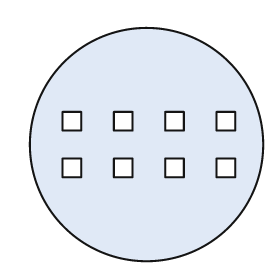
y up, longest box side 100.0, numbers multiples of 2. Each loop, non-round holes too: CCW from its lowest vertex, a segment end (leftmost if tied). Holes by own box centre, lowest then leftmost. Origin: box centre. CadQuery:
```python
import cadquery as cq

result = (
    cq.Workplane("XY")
    .moveTo(0.0, 0.0)
    .circle(50.0)
    .moveTo(-36.0, -14.0)
    .lineTo(-28.0, -14.0)
    .lineTo(-28.0, -6.0)
    .lineTo(-36.0, -6.0)
    .close()
    .moveTo(-14.0, -14.0)
    .lineTo(-6.0, -14.0)
    .lineTo(-6.0, -6.0)
    .lineTo(-14.0, -6.0)
    .close()
    .moveTo(8.0, -14.0)
    .lineTo(16.0, -14.0)
    .lineTo(16.0, -6.0)
    .lineTo(8.0, -6.0)
    .close()
    .moveTo(30.0, -14.0)
    .lineTo(38.0, -14.0)
    .lineTo(38.0, -6.0)
    .lineTo(30.0, -6.0)
    .close()
    .moveTo(-36.0, 6.0)
    .lineTo(-28.0, 6.0)
    .lineTo(-28.0, 14.0)
    .lineTo(-36.0, 14.0)
    .close()
    .moveTo(-14.0, 6.0)
    .lineTo(-6.0, 6.0)
    .lineTo(-6.0, 14.0)
    .lineTo(-14.0, 14.0)
    .close()
    .moveTo(8.0, 6.0)
    .lineTo(16.0, 6.0)
    .lineTo(16.0, 14.0)
    .lineTo(8.0, 14.0)
    .close()
    .moveTo(30.0, 6.0)
    .lineTo(38.0, 6.0)
    .lineTo(38.0, 14.0)
    .lineTo(30.0, 14.0)
    .close()
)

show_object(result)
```